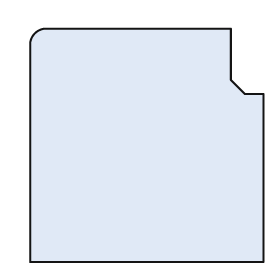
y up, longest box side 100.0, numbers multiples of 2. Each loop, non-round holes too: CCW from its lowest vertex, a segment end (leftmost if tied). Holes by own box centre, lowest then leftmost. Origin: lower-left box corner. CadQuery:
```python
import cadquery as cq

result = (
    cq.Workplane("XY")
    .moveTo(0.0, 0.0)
    .lineTo(100.0, 0.0)
    .lineTo(100.0, 72.0)
    .lineTo(92.0, 72.0)
    .lineTo(86.0, 78.0)
    .lineTo(86.0, 100.0)
    .lineTo(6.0, 100.0)
    .threePointArc((2.0, 98.0), (0.0, 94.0))
    .close()
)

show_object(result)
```